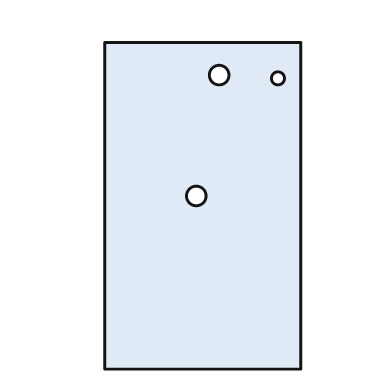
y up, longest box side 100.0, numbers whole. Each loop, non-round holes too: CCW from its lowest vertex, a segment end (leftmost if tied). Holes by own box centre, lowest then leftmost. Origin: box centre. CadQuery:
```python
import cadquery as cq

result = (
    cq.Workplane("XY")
    .moveTo(-30.0, -50.0)
    .lineTo(30.0, -50.0)
    .lineTo(30.0, 50.0)
    .lineTo(-30.0, 50.0)
    .close()
    .moveTo(-2.0, 3.0)
    .circle(3.0)
    .moveTo(23.0, 39.0)
    .circle(2.0)
    .moveTo(5.0, 40.0)
    .circle(3.0)
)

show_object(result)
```